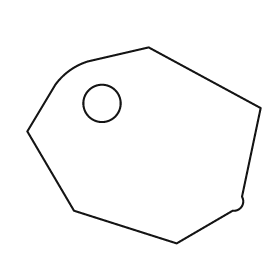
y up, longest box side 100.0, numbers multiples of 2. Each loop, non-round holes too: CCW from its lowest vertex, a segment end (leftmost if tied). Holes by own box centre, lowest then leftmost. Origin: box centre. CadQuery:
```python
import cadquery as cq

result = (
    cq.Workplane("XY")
    .moveTo(14.0, -42.0)
    .lineTo(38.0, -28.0)
    .threePointArc((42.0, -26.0), (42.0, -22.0))
    .lineTo(50.0, 16.0)
    .lineTo(2.0, 42.0)
    .lineTo(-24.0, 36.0)
    .threePointArc((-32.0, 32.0), (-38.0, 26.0))
    .lineTo(-50.0, 6.0)
    .lineTo(-30.0, -28.0)
    .close()
    .moveTo(-18.0, 18.0)
    .circle(8.0)
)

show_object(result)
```